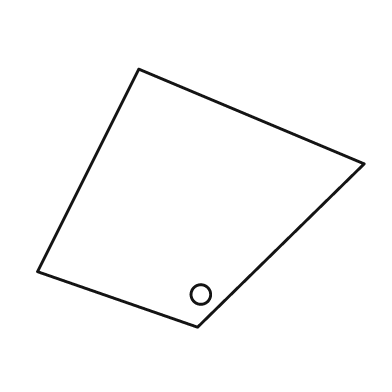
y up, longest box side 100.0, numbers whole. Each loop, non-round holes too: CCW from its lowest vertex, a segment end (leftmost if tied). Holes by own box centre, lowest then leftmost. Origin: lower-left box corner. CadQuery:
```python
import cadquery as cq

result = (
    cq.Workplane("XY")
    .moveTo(49.0, 0.0)
    .lineTo(100.0, 50.0)
    .lineTo(31.0, 79.0)
    .lineTo(0.0, 17.0)
    .close()
    .moveTo(50.0, 10.0)
    .circle(3.0)
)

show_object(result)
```